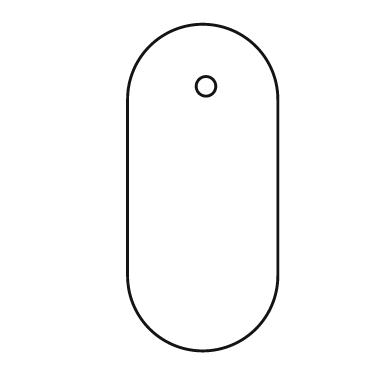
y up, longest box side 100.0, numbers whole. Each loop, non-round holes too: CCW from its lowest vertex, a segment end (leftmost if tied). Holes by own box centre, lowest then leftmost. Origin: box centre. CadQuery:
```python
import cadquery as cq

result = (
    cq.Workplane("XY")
    .moveTo(-23.0, -27.0)
    .threePointArc((0.0, -50.0), (23.0, -27.0))
    .lineTo(23.0, 27.0)
    .threePointArc((0.0, 50.0), (-23.0, 27.0))
    .close()
    .moveTo(1.0, 31.0)
    .circle(3.0)
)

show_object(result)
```